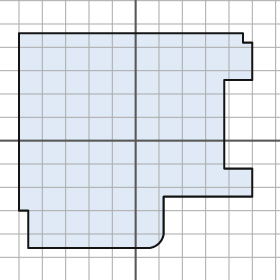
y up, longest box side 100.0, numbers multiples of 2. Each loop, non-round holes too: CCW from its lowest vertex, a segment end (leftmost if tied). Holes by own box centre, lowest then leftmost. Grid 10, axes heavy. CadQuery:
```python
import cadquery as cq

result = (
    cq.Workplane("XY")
    .moveTo(-46.0, -46.0)
    .lineTo(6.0, -46.0)
    .threePointArc((10.0, -44.0), (12.0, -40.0))
    .lineTo(12.0, -24.0)
    .lineTo(50.0, -24.0)
    .lineTo(50.0, -12.0)
    .lineTo(38.0, -12.0)
    .lineTo(38.0, 26.0)
    .lineTo(50.0, 26.0)
    .lineTo(50.0, 42.0)
    .lineTo(46.0, 42.0)
    .lineTo(46.0, 46.0)
    .lineTo(-50.0, 46.0)
    .lineTo(-50.0, -30.0)
    .lineTo(-46.0, -30.0)
    .close()
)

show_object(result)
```